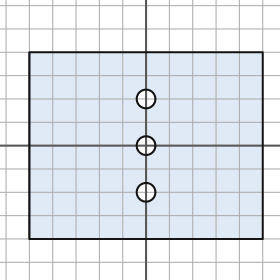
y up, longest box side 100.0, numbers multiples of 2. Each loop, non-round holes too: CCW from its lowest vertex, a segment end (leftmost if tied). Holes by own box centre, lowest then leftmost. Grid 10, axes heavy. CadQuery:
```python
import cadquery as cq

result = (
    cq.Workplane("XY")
    .moveTo(-50.0, -40.0)
    .lineTo(50.0, -40.0)
    .lineTo(50.0, 40.0)
    .lineTo(-50.0, 40.0)
    .close()
    .moveTo(0.0, -20.0)
    .circle(4.0)
    .moveTo(0.0, 0.0)
    .circle(4.0)
    .moveTo(0.0, 20.0)
    .circle(4.0)
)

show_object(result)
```